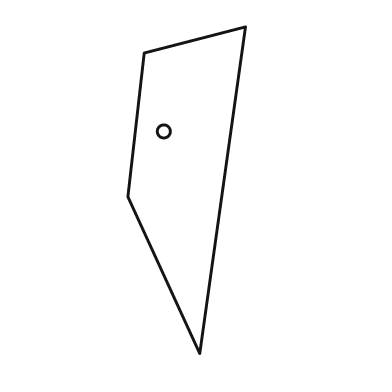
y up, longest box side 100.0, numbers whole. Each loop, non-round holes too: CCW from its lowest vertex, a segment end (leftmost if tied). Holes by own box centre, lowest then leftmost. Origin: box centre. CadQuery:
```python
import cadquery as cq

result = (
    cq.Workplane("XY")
    .moveTo(4.0, -50.0)
    .lineTo(18.0, 50.0)
    .lineTo(-13.0, 42.0)
    .lineTo(-18.0, -2.0)
    .close()
    .moveTo(-7.0, 18.0)
    .circle(2.0)
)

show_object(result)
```